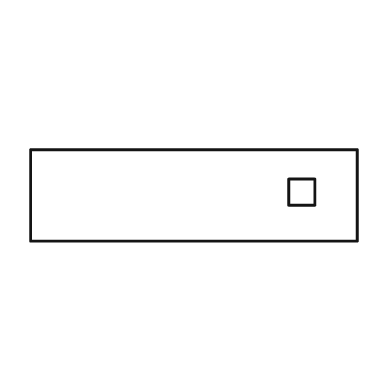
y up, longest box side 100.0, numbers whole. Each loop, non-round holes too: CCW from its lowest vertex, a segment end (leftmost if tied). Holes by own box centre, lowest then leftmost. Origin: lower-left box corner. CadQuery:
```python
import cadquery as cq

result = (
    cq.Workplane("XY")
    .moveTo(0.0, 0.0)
    .lineTo(100.0, 0.0)
    .lineTo(100.0, 28.0)
    .lineTo(0.0, 28.0)
    .close()
    .moveTo(79.0, 11.0)
    .lineTo(87.0, 11.0)
    .lineTo(87.0, 19.0)
    .lineTo(79.0, 19.0)
    .close()
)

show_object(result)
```